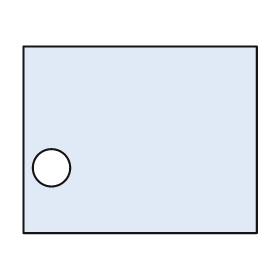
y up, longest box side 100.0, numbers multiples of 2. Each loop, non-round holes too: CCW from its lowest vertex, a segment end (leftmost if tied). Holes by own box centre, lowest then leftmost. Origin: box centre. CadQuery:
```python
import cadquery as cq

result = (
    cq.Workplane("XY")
    .moveTo(-50.0, -40.0)
    .lineTo(50.0, -40.0)
    .lineTo(50.0, 40.0)
    .lineTo(-50.0, 40.0)
    .close()
    .moveTo(-38.0, -12.0)
    .circle(8.0)
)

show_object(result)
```